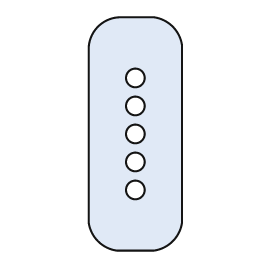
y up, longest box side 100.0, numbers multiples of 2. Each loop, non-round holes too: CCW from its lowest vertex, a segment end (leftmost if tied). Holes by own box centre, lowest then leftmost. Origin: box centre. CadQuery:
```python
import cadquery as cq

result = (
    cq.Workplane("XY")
    .moveTo(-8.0, -50.0)
    .lineTo(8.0, -50.0)
    .threePointArc((16.0, -46.0), (20.0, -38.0))
    .lineTo(20.0, 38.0)
    .threePointArc((16.0, 46.0), (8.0, 50.0))
    .lineTo(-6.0, 50.0)
    .threePointArc((-16.0, 46.0), (-20.0, 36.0))
    .lineTo(-20.0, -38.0)
    .threePointArc((-16.0, -46.0), (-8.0, -50.0))
    .close()
    .moveTo(0.0, -24.0)
    .circle(4.0)
    .moveTo(0.0, -12.0)
    .circle(4.0)
    .moveTo(0.0, 0.0)
    .circle(4.0)
    .moveTo(0.0, 12.0)
    .circle(4.0)
    .moveTo(0.0, 24.0)
    .circle(4.0)
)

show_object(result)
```